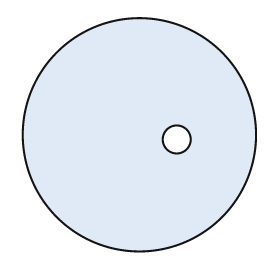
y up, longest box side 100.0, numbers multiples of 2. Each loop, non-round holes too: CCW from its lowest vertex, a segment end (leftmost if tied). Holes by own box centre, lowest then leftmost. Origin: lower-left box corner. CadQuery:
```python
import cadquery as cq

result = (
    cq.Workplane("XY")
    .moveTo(50.0, 50.0)
    .circle(50.0)
    .moveTo(66.0, 48.0)
    .circle(6.0)
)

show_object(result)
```